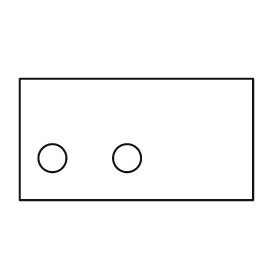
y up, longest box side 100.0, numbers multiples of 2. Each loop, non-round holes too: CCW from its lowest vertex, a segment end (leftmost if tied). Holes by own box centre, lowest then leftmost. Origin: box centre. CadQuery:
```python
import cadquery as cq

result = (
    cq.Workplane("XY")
    .moveTo(-50.0, -26.0)
    .lineTo(50.0, -26.0)
    .lineTo(50.0, 26.0)
    .lineTo(-50.0, 26.0)
    .close()
    .moveTo(-36.0, -8.0)
    .circle(6.0)
    .moveTo(-4.0, -8.0)
    .circle(6.0)
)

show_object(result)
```